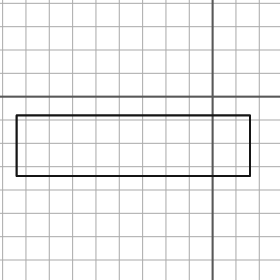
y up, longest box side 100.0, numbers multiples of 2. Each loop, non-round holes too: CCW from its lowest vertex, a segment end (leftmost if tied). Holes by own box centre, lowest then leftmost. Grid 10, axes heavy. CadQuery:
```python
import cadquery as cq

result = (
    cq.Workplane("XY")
    .moveTo(-84.0, -34.0)
    .lineTo(16.0, -34.0)
    .lineTo(16.0, -8.0)
    .lineTo(-84.0, -8.0)
    .close()
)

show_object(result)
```